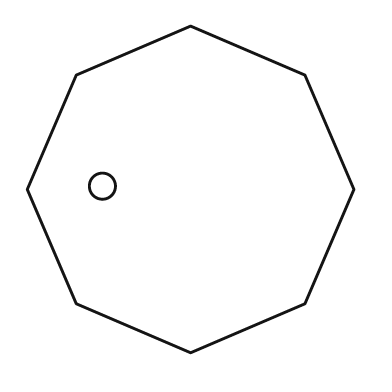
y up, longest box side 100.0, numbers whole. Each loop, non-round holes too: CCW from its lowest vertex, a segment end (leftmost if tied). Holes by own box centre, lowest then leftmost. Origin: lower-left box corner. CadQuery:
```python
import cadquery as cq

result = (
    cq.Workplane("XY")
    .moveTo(50.0, 0.0)
    .lineTo(85.0, 15.0)
    .lineTo(100.0, 50.0)
    .lineTo(85.0, 85.0)
    .lineTo(50.0, 100.0)
    .lineTo(15.0, 85.0)
    .lineTo(0.0, 50.0)
    .lineTo(15.0, 15.0)
    .close()
    .moveTo(23.0, 51.0)
    .circle(4.0)
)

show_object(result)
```